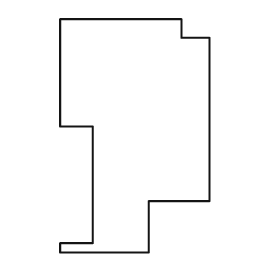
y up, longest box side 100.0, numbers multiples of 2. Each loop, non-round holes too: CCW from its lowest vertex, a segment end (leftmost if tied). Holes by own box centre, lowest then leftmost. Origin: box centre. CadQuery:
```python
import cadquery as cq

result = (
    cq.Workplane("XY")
    .moveTo(-32.0, -50.0)
    .lineTo(6.0, -50.0)
    .lineTo(6.0, -28.0)
    .lineTo(32.0, -28.0)
    .lineTo(32.0, 42.0)
    .lineTo(20.0, 42.0)
    .lineTo(20.0, 50.0)
    .lineTo(-32.0, 50.0)
    .lineTo(-32.0, 4.0)
    .lineTo(-18.0, 4.0)
    .lineTo(-18.0, -46.0)
    .lineTo(-32.0, -46.0)
    .close()
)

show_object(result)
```